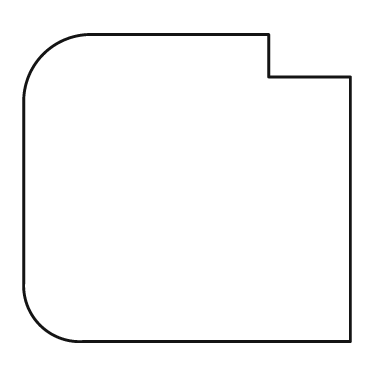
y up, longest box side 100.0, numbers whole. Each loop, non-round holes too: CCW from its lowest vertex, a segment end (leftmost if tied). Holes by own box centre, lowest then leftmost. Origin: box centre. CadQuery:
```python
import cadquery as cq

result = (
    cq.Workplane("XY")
    .moveTo(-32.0, -47.0)
    .lineTo(50.0, -47.0)
    .lineTo(50.0, 34.0)
    .lineTo(25.0, 34.0)
    .lineTo(25.0, 47.0)
    .lineTo(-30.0, 47.0)
    .threePointArc((-44.0, 41.0), (-50.0, 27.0))
    .lineTo(-50.0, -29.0)
    .threePointArc((-45.0, -42.0), (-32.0, -47.0))
    .close()
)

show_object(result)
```